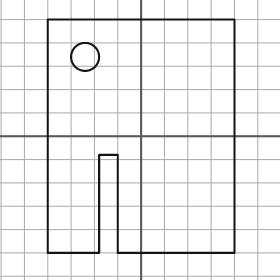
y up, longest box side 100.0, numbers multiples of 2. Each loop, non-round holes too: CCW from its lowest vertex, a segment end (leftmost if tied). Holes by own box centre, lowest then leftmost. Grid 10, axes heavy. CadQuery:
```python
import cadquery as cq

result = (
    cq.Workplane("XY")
    .moveTo(-40.0, -50.0)
    .lineTo(-18.0, -50.0)
    .lineTo(-18.0, -8.0)
    .lineTo(-10.0, -8.0)
    .lineTo(-10.0, -50.0)
    .lineTo(40.0, -50.0)
    .lineTo(40.0, 50.0)
    .lineTo(-40.0, 50.0)
    .close()
    .moveTo(-24.0, 34.0)
    .circle(6.0)
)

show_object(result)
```